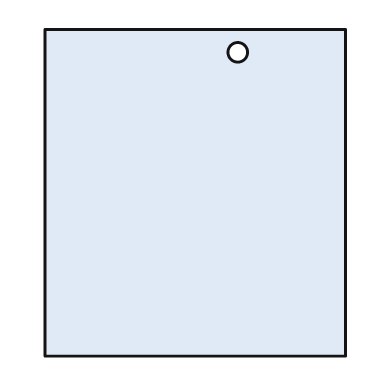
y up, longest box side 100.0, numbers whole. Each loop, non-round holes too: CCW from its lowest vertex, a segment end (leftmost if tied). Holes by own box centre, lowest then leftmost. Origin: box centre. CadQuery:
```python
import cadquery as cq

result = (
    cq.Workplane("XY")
    .moveTo(-46.0, -50.0)
    .lineTo(46.0, -50.0)
    .lineTo(46.0, 50.0)
    .lineTo(-46.0, 50.0)
    .close()
    .moveTo(13.0, 43.0)
    .circle(3.0)
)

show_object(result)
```